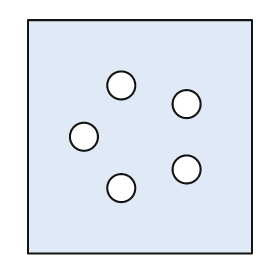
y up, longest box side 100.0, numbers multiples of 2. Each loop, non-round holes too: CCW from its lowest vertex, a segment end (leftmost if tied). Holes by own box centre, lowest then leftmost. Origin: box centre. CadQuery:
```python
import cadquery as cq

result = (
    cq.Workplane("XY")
    .moveTo(-48.0, -50.0)
    .lineTo(48.0, -50.0)
    .lineTo(48.0, 50.0)
    .lineTo(-48.0, 50.0)
    .close()
    .moveTo(-8.0, -22.0)
    .circle(6.0)
    .moveTo(20.0, -14.0)
    .circle(6.0)
    .moveTo(-24.0, 0.0)
    .circle(6.0)
    .moveTo(20.0, 14.0)
    .circle(6.0)
    .moveTo(-8.0, 22.0)
    .circle(6.0)
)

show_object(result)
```